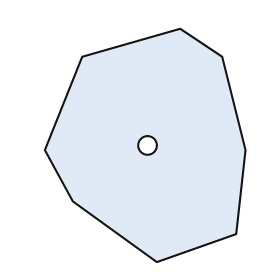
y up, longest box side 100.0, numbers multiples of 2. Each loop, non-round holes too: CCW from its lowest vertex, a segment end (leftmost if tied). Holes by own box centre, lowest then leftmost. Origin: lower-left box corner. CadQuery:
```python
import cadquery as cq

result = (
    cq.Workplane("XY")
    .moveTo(48.0, 0.0)
    .lineTo(82.0, 12.0)
    .lineTo(86.0, 48.0)
    .lineTo(76.0, 88.0)
    .lineTo(58.0, 100.0)
    .lineTo(16.0, 88.0)
    .lineTo(0.0, 48.0)
    .lineTo(12.0, 26.0)
    .close()
    .moveTo(44.0, 50.0)
    .circle(4.0)
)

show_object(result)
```